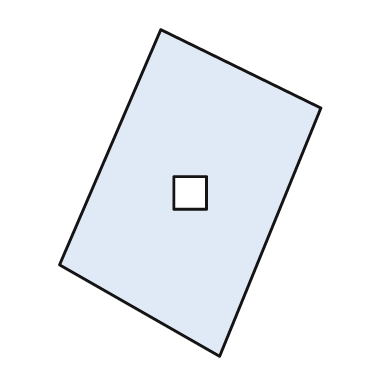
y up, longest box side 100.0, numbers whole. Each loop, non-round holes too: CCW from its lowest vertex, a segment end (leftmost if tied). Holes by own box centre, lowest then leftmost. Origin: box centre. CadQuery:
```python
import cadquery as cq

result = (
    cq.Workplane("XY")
    .moveTo(9.0, -50.0)
    .lineTo(40.0, 26.0)
    .lineTo(-9.0, 50.0)
    .lineTo(-40.0, -22.0)
    .close()
    .moveTo(-5.0, -5.0)
    .lineTo(5.0, -5.0)
    .lineTo(5.0, 5.0)
    .lineTo(-5.0, 5.0)
    .close()
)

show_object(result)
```